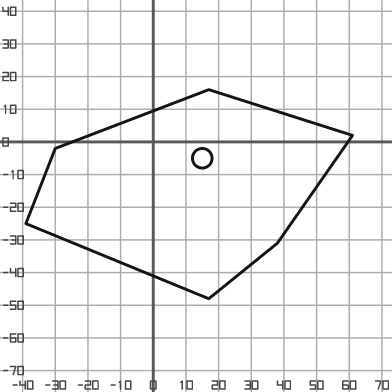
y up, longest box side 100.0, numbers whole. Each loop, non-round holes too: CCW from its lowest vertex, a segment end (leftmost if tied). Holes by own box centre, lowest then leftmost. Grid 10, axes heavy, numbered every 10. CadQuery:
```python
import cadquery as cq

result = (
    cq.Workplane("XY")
    .moveTo(17.0, -48.0)
    .lineTo(38.0, -31.0)
    .lineTo(61.0, 2.0)
    .lineTo(17.0, 16.0)
    .lineTo(-30.0, -2.0)
    .lineTo(-39.0, -25.0)
    .close()
    .moveTo(15.0, -5.0)
    .circle(3.0)
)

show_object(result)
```